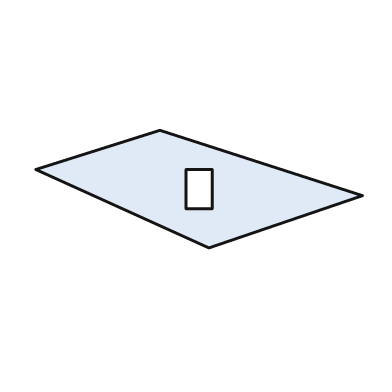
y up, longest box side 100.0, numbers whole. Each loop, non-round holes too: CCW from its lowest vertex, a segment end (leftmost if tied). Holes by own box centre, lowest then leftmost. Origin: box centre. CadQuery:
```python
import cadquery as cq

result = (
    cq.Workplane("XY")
    .moveTo(3.0, -18.0)
    .lineTo(50.0, -2.0)
    .lineTo(-12.0, 18.0)
    .lineTo(-50.0, 6.0)
    .close()
    .moveTo(-4.0, -6.0)
    .lineTo(4.0, -6.0)
    .lineTo(4.0, 6.0)
    .lineTo(-4.0, 6.0)
    .close()
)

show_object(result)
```